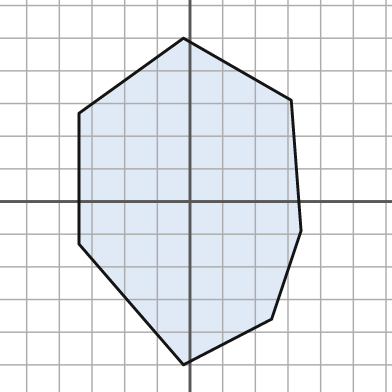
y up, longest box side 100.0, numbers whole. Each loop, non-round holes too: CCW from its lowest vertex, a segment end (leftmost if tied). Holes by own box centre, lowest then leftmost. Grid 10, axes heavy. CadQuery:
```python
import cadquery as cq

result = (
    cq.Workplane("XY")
    .moveTo(-2.0, -50.0)
    .lineTo(25.0, -36.0)
    .lineTo(34.0, -9.0)
    .lineTo(31.0, 31.0)
    .lineTo(-2.0, 50.0)
    .lineTo(-34.0, 27.0)
    .lineTo(-34.0, -13.0)
    .close()
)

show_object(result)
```